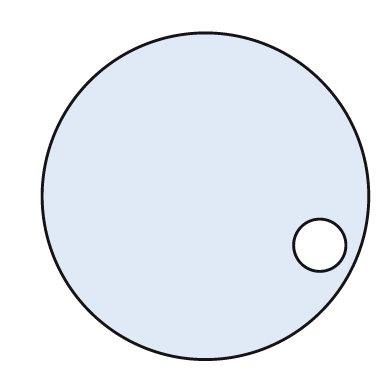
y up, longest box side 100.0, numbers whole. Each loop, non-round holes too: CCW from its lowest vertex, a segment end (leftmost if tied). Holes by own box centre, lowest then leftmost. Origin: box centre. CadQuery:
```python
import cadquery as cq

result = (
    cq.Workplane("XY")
    .moveTo(0.0, 0.0)
    .circle(50.0)
    .moveTo(35.0, -15.0)
    .circle(8.0)
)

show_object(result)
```